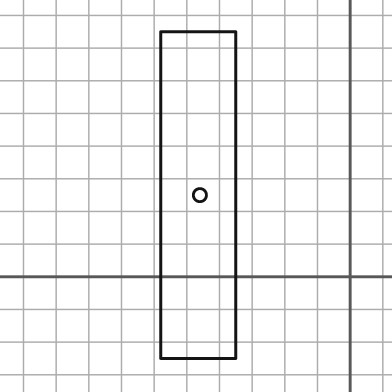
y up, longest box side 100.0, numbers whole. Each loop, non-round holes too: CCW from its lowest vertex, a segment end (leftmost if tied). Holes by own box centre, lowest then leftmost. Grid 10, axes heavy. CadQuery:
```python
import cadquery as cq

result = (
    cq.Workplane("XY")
    .moveTo(-58.0, -25.0)
    .lineTo(-35.0, -25.0)
    .lineTo(-35.0, 75.0)
    .lineTo(-58.0, 75.0)
    .close()
    .moveTo(-46.0, 25.0)
    .circle(2.0)
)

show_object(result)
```